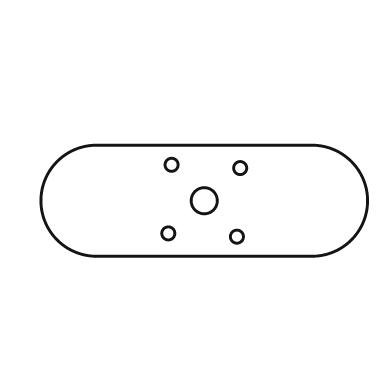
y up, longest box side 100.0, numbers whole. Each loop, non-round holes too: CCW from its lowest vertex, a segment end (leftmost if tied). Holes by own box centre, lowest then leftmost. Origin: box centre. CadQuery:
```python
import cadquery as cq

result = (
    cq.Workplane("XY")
    .moveTo(-33.0, -17.0)
    .lineTo(33.0, -17.0)
    .threePointArc((50.0, 0.0), (33.0, 17.0))
    .lineTo(-33.0, 17.0)
    .threePointArc((-50.0, 0.0), (-33.0, -17.0))
    .close()
    .moveTo(10.0, -11.0)
    .circle(2.0)
    .moveTo(-11.0, -10.0)
    .circle(2.0)
    .moveTo(0.0, 0.0)
    .circle(4.0)
    .moveTo(11.0, 10.0)
    .circle(2.0)
    .moveTo(-10.0, 11.0)
    .circle(2.0)
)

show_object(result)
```